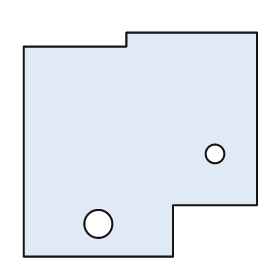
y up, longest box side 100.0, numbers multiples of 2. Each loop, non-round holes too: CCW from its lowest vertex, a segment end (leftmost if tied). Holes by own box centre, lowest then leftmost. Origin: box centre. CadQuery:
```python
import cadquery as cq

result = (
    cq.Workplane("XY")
    .moveTo(-50.0, -48.0)
    .lineTo(14.0, -48.0)
    .lineTo(14.0, -26.0)
    .lineTo(50.0, -26.0)
    .lineTo(50.0, 48.0)
    .lineTo(-6.0, 48.0)
    .lineTo(-6.0, 42.0)
    .lineTo(-50.0, 42.0)
    .close()
    .moveTo(-18.0, -34.0)
    .circle(6.0)
    .moveTo(32.0, -4.0)
    .circle(4.0)
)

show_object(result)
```